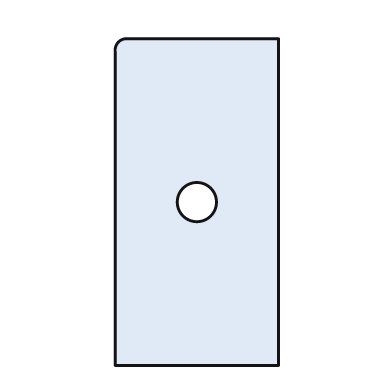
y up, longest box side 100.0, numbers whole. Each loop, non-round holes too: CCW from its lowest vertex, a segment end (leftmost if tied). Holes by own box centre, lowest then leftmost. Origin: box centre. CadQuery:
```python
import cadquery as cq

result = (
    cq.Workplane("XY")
    .moveTo(-25.0, -50.0)
    .lineTo(25.0, -50.0)
    .lineTo(25.0, 50.0)
    .lineTo(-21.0, 50.0)
    .threePointArc((-24.0, 49.0), (-25.0, 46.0))
    .close()
    .moveTo(0.0, 0.0)
    .circle(6.0)
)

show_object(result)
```